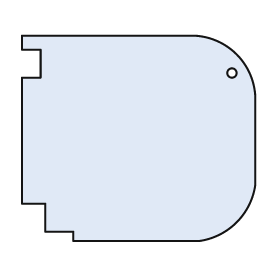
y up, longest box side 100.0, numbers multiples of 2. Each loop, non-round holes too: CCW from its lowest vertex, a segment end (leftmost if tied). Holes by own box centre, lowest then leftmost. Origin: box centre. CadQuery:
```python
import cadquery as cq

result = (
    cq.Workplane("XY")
    .moveTo(-28.0, -44.0)
    .lineTo(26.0, -44.0)
    .threePointArc((42.0, -36.0), (50.0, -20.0))
    .lineTo(50.0, 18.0)
    .threePointArc((42.0, 36.0), (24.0, 44.0))
    .lineTo(-50.0, 44.0)
    .lineTo(-50.0, 38.0)
    .lineTo(-42.0, 38.0)
    .lineTo(-42.0, 26.0)
    .lineTo(-50.0, 26.0)
    .lineTo(-50.0, -28.0)
    .lineTo(-40.0, -28.0)
    .lineTo(-40.0, -40.0)
    .lineTo(-28.0, -40.0)
    .close()
    .moveTo(40.0, 28.0)
    .circle(2.0)
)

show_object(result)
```